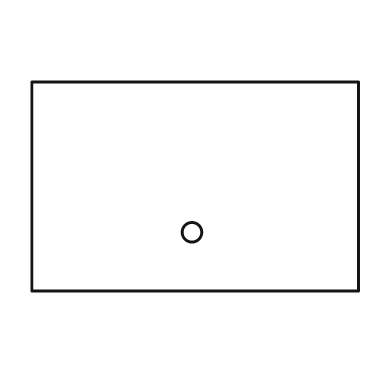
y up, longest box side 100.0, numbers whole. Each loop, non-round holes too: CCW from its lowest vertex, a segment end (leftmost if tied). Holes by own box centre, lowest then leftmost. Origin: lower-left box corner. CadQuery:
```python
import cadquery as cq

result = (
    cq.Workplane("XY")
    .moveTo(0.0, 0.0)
    .lineTo(100.0, 0.0)
    .lineTo(100.0, 64.0)
    .lineTo(0.0, 64.0)
    .close()
    .moveTo(49.0, 18.0)
    .circle(3.0)
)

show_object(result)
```